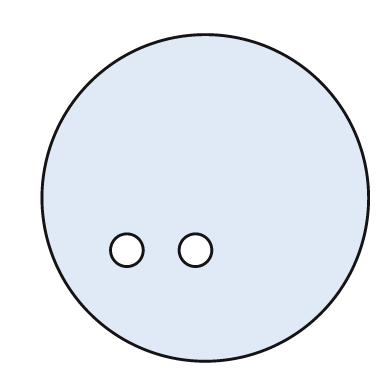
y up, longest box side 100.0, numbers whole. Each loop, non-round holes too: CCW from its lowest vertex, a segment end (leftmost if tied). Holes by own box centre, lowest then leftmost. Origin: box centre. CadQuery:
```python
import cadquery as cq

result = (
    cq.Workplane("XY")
    .moveTo(0.0, 0.0)
    .circle(50.0)
    .moveTo(-24.0, -16.0)
    .circle(5.0)
    .moveTo(-3.0, -16.0)
    .circle(5.0)
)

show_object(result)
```